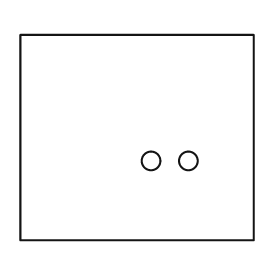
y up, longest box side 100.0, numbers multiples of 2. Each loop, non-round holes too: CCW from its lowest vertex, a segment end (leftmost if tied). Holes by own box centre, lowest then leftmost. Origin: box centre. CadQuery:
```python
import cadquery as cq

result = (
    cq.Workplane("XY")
    .moveTo(-50.0, -44.0)
    .lineTo(50.0, -44.0)
    .lineTo(50.0, 44.0)
    .lineTo(-50.0, 44.0)
    .close()
    .moveTo(6.0, -10.0)
    .circle(4.0)
    .moveTo(22.0, -10.0)
    .circle(4.0)
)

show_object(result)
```